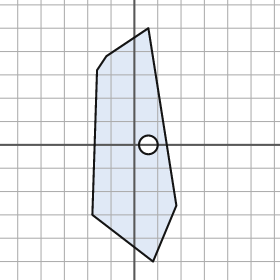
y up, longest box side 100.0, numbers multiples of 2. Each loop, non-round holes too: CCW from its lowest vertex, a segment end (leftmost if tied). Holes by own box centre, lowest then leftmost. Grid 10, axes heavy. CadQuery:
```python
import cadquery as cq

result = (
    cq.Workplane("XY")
    .moveTo(8.0, -50.0)
    .lineTo(18.0, -26.0)
    .lineTo(6.0, 50.0)
    .lineTo(-12.0, 38.0)
    .lineTo(-16.0, 32.0)
    .lineTo(-18.0, -30.0)
    .close()
    .moveTo(6.0, 0.0)
    .circle(4.0)
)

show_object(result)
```